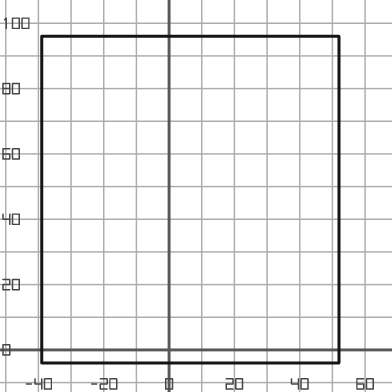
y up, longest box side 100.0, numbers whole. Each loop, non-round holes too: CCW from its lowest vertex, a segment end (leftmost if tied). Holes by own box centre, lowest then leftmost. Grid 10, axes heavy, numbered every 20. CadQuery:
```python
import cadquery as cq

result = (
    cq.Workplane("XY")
    .moveTo(-39.0, -4.0)
    .lineTo(52.0, -4.0)
    .lineTo(52.0, 96.0)
    .lineTo(-39.0, 96.0)
    .close()
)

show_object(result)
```